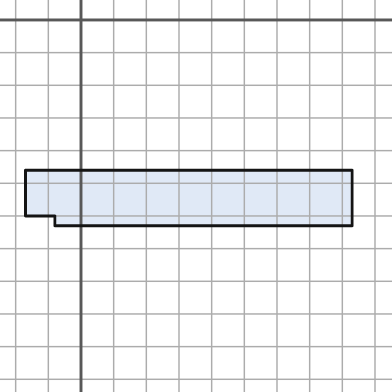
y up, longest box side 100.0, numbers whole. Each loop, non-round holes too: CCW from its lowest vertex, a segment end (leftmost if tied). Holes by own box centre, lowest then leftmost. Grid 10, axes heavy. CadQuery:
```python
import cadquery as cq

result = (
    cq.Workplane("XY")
    .moveTo(-8.0, -63.0)
    .lineTo(83.0, -63.0)
    .lineTo(83.0, -46.0)
    .lineTo(-17.0, -46.0)
    .lineTo(-17.0, -60.0)
    .lineTo(-8.0, -60.0)
    .close()
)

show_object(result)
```